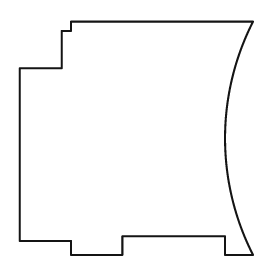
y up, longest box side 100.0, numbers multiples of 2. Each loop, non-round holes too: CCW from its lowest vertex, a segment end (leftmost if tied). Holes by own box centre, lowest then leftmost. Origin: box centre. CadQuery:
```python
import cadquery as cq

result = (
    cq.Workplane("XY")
    .moveTo(-28.0, -50.0)
    .lineTo(-6.0, -50.0)
    .lineTo(-6.0, -42.0)
    .lineTo(38.0, -42.0)
    .lineTo(38.0, -50.0)
    .lineTo(50.0, -50.0)
    .threePointArc((38.0, 0.0), (50.0, 50.0))
    .lineTo(-28.0, 50.0)
    .lineTo(-28.0, 46.0)
    .lineTo(-32.0, 46.0)
    .lineTo(-32.0, 30.0)
    .lineTo(-50.0, 30.0)
    .lineTo(-50.0, -44.0)
    .lineTo(-28.0, -44.0)
    .close()
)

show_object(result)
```